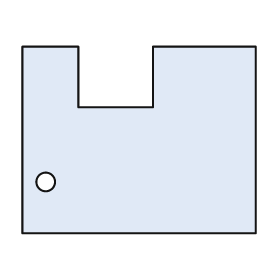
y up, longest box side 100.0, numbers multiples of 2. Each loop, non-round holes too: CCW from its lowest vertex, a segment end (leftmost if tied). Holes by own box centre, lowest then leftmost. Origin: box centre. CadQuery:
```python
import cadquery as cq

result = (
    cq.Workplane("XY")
    .moveTo(-50.0, -40.0)
    .lineTo(50.0, -40.0)
    .lineTo(50.0, 40.0)
    .lineTo(6.0, 40.0)
    .lineTo(6.0, 14.0)
    .lineTo(-26.0, 14.0)
    .lineTo(-26.0, 40.0)
    .lineTo(-50.0, 40.0)
    .close()
    .moveTo(-40.0, -18.0)
    .circle(4.0)
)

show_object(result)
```